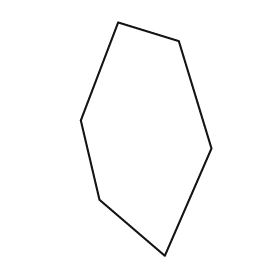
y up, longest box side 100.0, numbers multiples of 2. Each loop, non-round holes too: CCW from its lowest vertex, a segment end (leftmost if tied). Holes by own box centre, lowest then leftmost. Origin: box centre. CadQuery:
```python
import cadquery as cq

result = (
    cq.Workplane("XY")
    .moveTo(8.0, -50.0)
    .lineTo(28.0, -4.0)
    .lineTo(14.0, 42.0)
    .lineTo(-12.0, 50.0)
    .lineTo(-28.0, 8.0)
    .lineTo(-20.0, -26.0)
    .close()
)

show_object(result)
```